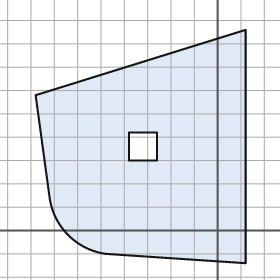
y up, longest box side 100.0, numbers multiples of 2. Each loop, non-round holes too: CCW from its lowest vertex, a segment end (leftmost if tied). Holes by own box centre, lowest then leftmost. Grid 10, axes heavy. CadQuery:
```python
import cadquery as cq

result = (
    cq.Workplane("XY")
    .moveTo(12.0, -14.0)
    .lineTo(12.0, 86.0)
    .lineTo(-78.0, 58.0)
    .lineTo(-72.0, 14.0)
    .threePointArc((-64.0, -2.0), (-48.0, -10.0))
    .close()
    .moveTo(-38.0, 30.0)
    .lineTo(-26.0, 30.0)
    .lineTo(-26.0, 42.0)
    .lineTo(-38.0, 42.0)
    .close()
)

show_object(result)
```